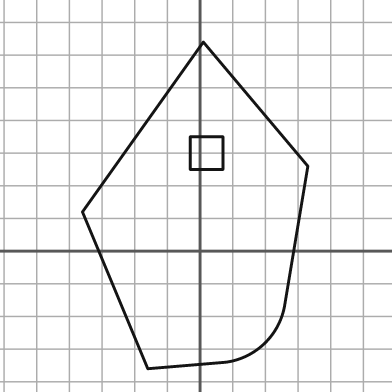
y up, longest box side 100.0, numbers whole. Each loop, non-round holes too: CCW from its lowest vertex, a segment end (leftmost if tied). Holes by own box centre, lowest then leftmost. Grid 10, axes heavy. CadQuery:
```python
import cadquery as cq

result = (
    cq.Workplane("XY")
    .moveTo(-16.0, -36.0)
    .lineTo(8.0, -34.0)
    .threePointArc((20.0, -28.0), (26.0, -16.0))
    .lineTo(33.0, 26.0)
    .lineTo(1.0, 64.0)
    .lineTo(-36.0, 12.0)
    .close()
    .moveTo(-3.0, 25.0)
    .lineTo(7.0, 25.0)
    .lineTo(7.0, 35.0)
    .lineTo(-3.0, 35.0)
    .close()
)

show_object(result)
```